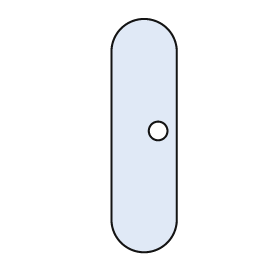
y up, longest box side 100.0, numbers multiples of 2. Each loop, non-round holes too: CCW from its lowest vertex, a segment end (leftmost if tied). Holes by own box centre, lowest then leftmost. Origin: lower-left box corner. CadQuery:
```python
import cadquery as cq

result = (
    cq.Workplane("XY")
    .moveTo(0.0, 14.0)
    .threePointArc((14.0, 0.0), (28.0, 14.0))
    .lineTo(28.0, 86.0)
    .threePointArc((14.0, 100.0), (0.0, 86.0))
    .close()
    .moveTo(20.0, 52.0)
    .circle(4.0)
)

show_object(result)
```